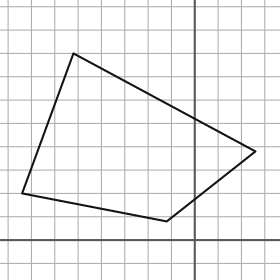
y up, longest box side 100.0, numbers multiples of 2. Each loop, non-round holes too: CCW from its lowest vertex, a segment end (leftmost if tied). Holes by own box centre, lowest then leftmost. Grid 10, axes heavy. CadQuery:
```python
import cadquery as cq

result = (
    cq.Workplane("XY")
    .moveTo(-12.0, 8.0)
    .lineTo(26.0, 38.0)
    .lineTo(-52.0, 80.0)
    .lineTo(-74.0, 20.0)
    .close()
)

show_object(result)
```